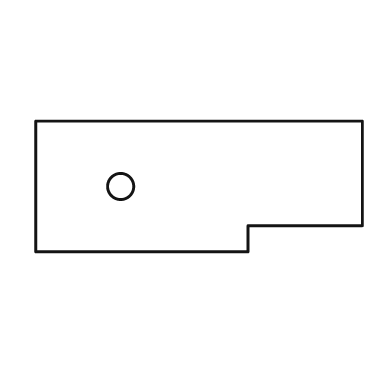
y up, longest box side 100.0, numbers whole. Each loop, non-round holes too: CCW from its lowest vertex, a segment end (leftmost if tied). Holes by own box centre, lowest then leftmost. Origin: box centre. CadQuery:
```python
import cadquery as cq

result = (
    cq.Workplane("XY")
    .moveTo(-50.0, -20.0)
    .lineTo(15.0, -20.0)
    .lineTo(15.0, -12.0)
    .lineTo(50.0, -12.0)
    .lineTo(50.0, 20.0)
    .lineTo(-50.0, 20.0)
    .close()
    .moveTo(-24.0, 0.0)
    .circle(4.0)
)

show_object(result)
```